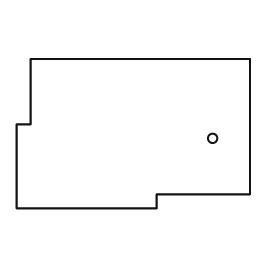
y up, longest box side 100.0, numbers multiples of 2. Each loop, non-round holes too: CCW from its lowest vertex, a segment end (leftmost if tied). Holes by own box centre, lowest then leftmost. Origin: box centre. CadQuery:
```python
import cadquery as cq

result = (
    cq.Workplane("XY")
    .moveTo(-50.0, -32.0)
    .lineTo(10.0, -32.0)
    .lineTo(10.0, -26.0)
    .lineTo(50.0, -26.0)
    .lineTo(50.0, 32.0)
    .lineTo(-44.0, 32.0)
    .lineTo(-44.0, 4.0)
    .lineTo(-50.0, 4.0)
    .close()
    .moveTo(34.0, -2.0)
    .circle(2.0)
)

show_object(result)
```